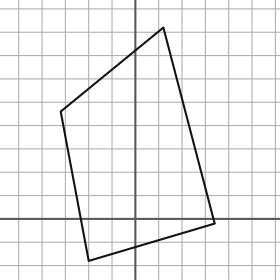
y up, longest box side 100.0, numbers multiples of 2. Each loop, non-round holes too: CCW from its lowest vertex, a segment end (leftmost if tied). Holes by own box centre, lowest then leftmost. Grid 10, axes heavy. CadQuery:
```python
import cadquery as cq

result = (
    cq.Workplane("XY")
    .moveTo(-20.0, -18.0)
    .lineTo(34.0, -2.0)
    .lineTo(12.0, 82.0)
    .lineTo(-32.0, 46.0)
    .close()
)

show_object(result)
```